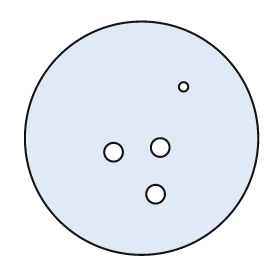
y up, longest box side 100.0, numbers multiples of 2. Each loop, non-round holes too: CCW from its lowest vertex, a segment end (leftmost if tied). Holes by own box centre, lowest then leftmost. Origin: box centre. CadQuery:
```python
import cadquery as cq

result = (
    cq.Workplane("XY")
    .moveTo(0.0, 0.0)
    .circle(50.0)
    .moveTo(6.0, -24.0)
    .circle(4.0)
    .moveTo(-12.0, -6.0)
    .circle(4.0)
    .moveTo(8.0, -4.0)
    .circle(4.0)
    .moveTo(18.0, 22.0)
    .circle(2.0)
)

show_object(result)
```